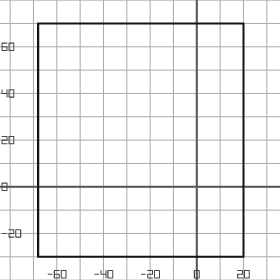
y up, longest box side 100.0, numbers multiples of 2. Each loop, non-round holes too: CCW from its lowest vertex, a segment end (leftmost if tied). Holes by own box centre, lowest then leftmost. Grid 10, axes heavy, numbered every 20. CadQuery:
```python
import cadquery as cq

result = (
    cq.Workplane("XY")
    .moveTo(-68.0, -30.0)
    .lineTo(20.0, -30.0)
    .lineTo(20.0, 70.0)
    .lineTo(-68.0, 70.0)
    .close()
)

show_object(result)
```